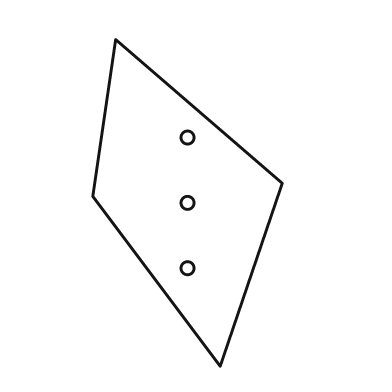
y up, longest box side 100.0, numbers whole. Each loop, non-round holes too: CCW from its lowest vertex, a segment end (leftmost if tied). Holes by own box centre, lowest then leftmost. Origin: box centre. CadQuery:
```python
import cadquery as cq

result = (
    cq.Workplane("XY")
    .moveTo(10.0, -50.0)
    .lineTo(29.0, 6.0)
    .lineTo(-22.0, 50.0)
    .lineTo(-29.0, 2.0)
    .close()
    .moveTo(0.0, -20.0)
    .circle(2.0)
    .moveTo(0.0, 0.0)
    .circle(2.0)
    .moveTo(0.0, 20.0)
    .circle(2.0)
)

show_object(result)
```